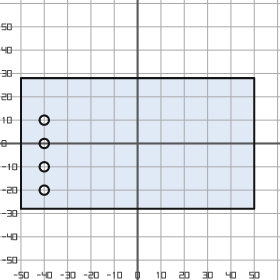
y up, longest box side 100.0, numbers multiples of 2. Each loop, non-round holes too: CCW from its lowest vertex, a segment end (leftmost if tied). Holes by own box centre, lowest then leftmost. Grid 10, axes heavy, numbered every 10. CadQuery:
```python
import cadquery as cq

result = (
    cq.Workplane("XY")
    .moveTo(-50.0, -28.0)
    .lineTo(50.0, -28.0)
    .lineTo(50.0, 28.0)
    .lineTo(-50.0, 28.0)
    .close()
    .moveTo(-40.0, -20.0)
    .circle(2.0)
    .moveTo(-40.0, -10.0)
    .circle(2.0)
    .moveTo(-40.0, 0.0)
    .circle(2.0)
    .moveTo(-40.0, 10.0)
    .circle(2.0)
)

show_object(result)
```